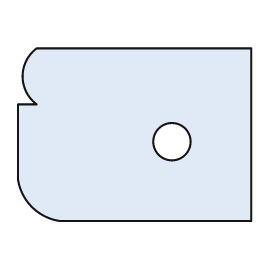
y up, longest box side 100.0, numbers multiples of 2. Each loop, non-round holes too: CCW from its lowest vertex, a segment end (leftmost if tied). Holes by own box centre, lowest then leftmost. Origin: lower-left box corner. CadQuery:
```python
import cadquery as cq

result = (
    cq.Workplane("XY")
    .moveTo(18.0, 0.0)
    .lineTo(100.0, 0.0)
    .lineTo(100.0, 74.0)
    .lineTo(8.0, 74.0)
    .threePointArc((2.0, 62.0), (8.0, 50.0))
    .lineTo(0.0, 50.0)
    .lineTo(0.0, 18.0)
    .threePointArc((6.0, 6.0), (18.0, 0.0))
    .close()
    .moveTo(66.0, 34.0)
    .circle(8.0)
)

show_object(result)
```